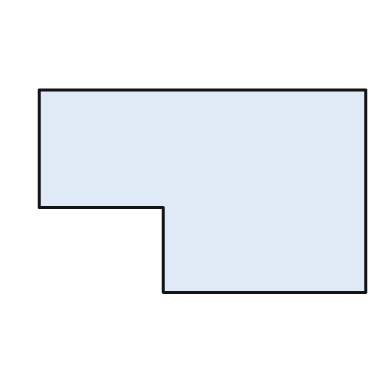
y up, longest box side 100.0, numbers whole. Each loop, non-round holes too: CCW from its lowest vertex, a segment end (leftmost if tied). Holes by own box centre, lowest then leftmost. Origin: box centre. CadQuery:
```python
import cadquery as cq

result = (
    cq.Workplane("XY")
    .moveTo(-12.0, -31.0)
    .lineTo(50.0, -31.0)
    .lineTo(50.0, 31.0)
    .lineTo(-50.0, 31.0)
    .lineTo(-50.0, -5.0)
    .lineTo(-12.0, -5.0)
    .close()
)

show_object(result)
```